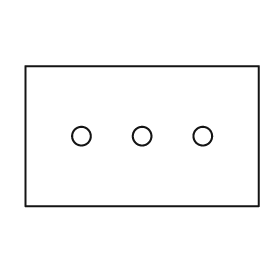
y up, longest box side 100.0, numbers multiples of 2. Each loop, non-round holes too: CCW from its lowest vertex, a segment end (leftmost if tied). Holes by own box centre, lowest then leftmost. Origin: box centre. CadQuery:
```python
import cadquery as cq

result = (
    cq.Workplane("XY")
    .moveTo(-50.0, -30.0)
    .lineTo(50.0, -30.0)
    .lineTo(50.0, 30.0)
    .lineTo(-50.0, 30.0)
    .close()
    .moveTo(-26.0, 0.0)
    .circle(4.0)
    .moveTo(0.0, 0.0)
    .circle(4.0)
    .moveTo(26.0, 0.0)
    .circle(4.0)
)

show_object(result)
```